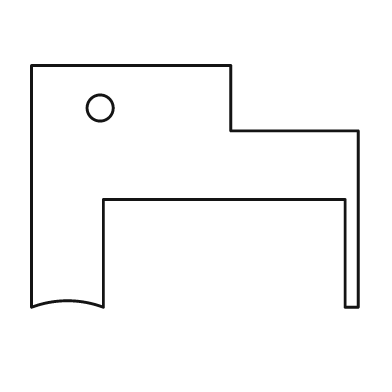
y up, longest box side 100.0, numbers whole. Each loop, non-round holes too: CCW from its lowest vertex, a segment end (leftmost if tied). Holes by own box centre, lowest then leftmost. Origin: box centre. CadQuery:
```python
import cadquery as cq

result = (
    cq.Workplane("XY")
    .moveTo(-50.0, -37.0)
    .threePointArc((-39.0, -35.0), (-28.0, -37.0))
    .lineTo(-28.0, -4.0)
    .lineTo(46.0, -4.0)
    .lineTo(46.0, -37.0)
    .lineTo(50.0, -37.0)
    .lineTo(50.0, 17.0)
    .lineTo(11.0, 17.0)
    .lineTo(11.0, 37.0)
    .lineTo(-50.0, 37.0)
    .close()
    .moveTo(-29.0, 24.0)
    .circle(4.0)
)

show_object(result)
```